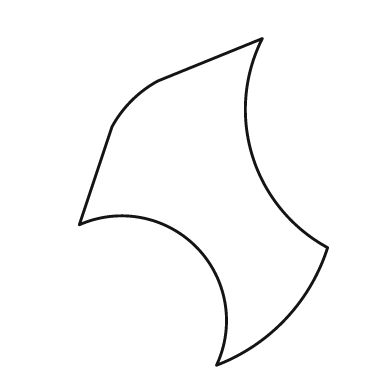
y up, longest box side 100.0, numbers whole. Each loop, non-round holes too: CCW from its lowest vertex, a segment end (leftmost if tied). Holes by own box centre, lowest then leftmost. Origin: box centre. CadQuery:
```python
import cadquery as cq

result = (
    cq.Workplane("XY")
    .moveTo(4.0, -50.0)
    .threePointArc((25.0, -36.0), (38.0, -14.0))
    .threePointArc((15.0, 14.0), (18.0, 50.0))
    .lineTo(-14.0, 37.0)
    .threePointArc((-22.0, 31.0), (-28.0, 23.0))
    .lineTo(-38.0, -7.0)
    .threePointArc((-2.0, -14.0), (4.0, -50.0))
    .close()
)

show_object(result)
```